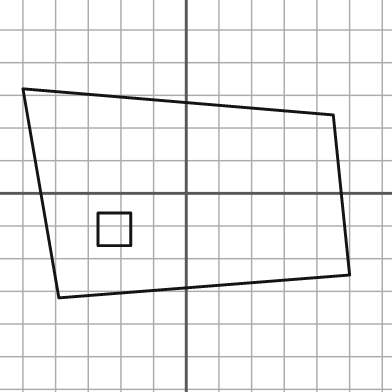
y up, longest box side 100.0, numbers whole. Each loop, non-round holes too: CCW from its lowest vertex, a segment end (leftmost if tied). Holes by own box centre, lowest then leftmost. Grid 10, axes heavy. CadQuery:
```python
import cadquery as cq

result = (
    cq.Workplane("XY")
    .moveTo(-39.0, -32.0)
    .lineTo(50.0, -25.0)
    .lineTo(45.0, 24.0)
    .lineTo(-50.0, 32.0)
    .close()
    .moveTo(-27.0, -16.0)
    .lineTo(-17.0, -16.0)
    .lineTo(-17.0, -6.0)
    .lineTo(-27.0, -6.0)
    .close()
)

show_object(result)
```